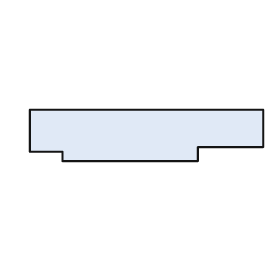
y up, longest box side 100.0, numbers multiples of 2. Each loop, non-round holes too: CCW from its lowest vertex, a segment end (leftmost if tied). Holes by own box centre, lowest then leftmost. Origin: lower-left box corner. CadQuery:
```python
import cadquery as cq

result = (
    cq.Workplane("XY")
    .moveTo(14.0, 0.0)
    .lineTo(72.0, 0.0)
    .lineTo(72.0, 6.0)
    .lineTo(100.0, 6.0)
    .lineTo(100.0, 22.0)
    .lineTo(0.0, 22.0)
    .lineTo(0.0, 4.0)
    .lineTo(14.0, 4.0)
    .close()
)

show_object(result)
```